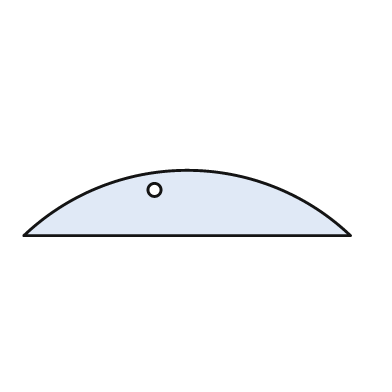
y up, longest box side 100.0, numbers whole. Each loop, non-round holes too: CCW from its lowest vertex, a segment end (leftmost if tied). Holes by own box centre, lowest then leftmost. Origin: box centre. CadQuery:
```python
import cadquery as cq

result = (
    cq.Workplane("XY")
    .moveTo(-50.0, -10.0)
    .lineTo(50.0, -10.0)
    .threePointArc((0.0, 10.0), (-50.0, -10.0))
    .close()
    .moveTo(-10.0, 4.0)
    .circle(2.0)
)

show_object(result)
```